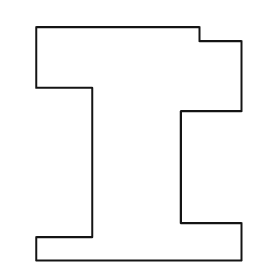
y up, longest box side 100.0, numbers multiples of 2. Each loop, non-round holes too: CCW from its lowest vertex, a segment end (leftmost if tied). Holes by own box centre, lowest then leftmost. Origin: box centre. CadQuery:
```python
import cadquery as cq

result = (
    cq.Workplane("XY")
    .moveTo(-44.0, -50.0)
    .lineTo(44.0, -50.0)
    .lineTo(44.0, -34.0)
    .lineTo(18.0, -34.0)
    .lineTo(18.0, 14.0)
    .lineTo(44.0, 14.0)
    .lineTo(44.0, 44.0)
    .lineTo(26.0, 44.0)
    .lineTo(26.0, 50.0)
    .lineTo(-44.0, 50.0)
    .lineTo(-44.0, 24.0)
    .lineTo(-20.0, 24.0)
    .lineTo(-20.0, -40.0)
    .lineTo(-44.0, -40.0)
    .close()
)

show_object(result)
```